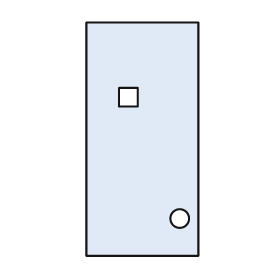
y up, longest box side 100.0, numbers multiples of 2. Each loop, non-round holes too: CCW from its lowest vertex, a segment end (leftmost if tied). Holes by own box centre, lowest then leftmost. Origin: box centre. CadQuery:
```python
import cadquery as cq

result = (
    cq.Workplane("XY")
    .moveTo(-24.0, -50.0)
    .lineTo(24.0, -50.0)
    .lineTo(24.0, 50.0)
    .lineTo(-24.0, 50.0)
    .close()
    .moveTo(16.0, -34.0)
    .circle(4.0)
    .moveTo(-10.0, 14.0)
    .lineTo(-2.0, 14.0)
    .lineTo(-2.0, 22.0)
    .lineTo(-10.0, 22.0)
    .close()
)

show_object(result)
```